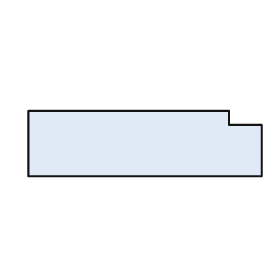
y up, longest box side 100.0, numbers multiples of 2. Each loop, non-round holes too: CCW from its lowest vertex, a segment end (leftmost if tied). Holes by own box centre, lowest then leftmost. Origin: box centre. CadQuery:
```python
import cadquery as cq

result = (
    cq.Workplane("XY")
    .moveTo(-50.0, -14.0)
    .lineTo(50.0, -14.0)
    .lineTo(50.0, 8.0)
    .lineTo(36.0, 8.0)
    .lineTo(36.0, 14.0)
    .lineTo(-50.0, 14.0)
    .close()
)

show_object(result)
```